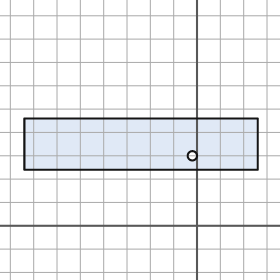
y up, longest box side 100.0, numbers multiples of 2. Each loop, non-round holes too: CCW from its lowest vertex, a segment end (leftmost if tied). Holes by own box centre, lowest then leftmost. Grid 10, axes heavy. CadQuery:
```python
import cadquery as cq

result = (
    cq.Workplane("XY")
    .moveTo(-74.0, 24.0)
    .lineTo(26.0, 24.0)
    .lineTo(26.0, 46.0)
    .lineTo(-74.0, 46.0)
    .close()
    .moveTo(-2.0, 30.0)
    .circle(2.0)
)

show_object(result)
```